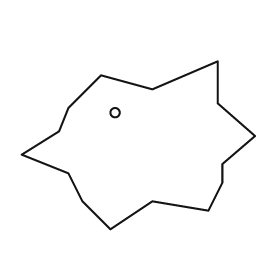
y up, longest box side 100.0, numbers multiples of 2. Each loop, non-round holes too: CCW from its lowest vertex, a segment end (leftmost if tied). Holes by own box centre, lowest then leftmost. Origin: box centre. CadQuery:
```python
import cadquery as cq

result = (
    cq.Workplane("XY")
    .moveTo(-12.0, -36.0)
    .lineTo(6.0, -24.0)
    .lineTo(30.0, -28.0)
    .lineTo(36.0, -16.0)
    .lineTo(36.0, -8.0)
    .lineTo(50.0, 4.0)
    .lineTo(34.0, 18.0)
    .lineTo(34.0, 36.0)
    .lineTo(6.0, 24.0)
    .lineTo(-16.0, 30.0)
    .lineTo(-30.0, 16.0)
    .lineTo(-34.0, 6.0)
    .lineTo(-50.0, -4.0)
    .lineTo(-30.0, -12.0)
    .lineTo(-24.0, -24.0)
    .close()
    .moveTo(-10.0, 14.0)
    .circle(2.0)
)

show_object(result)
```